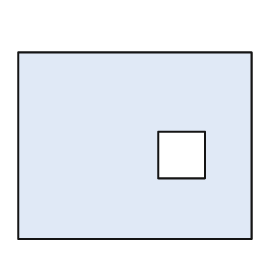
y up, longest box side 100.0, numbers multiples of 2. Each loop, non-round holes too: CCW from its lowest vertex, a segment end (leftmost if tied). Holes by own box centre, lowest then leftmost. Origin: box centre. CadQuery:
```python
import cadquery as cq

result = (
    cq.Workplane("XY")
    .moveTo(-50.0, -40.0)
    .lineTo(50.0, -40.0)
    .lineTo(50.0, 40.0)
    .lineTo(-50.0, 40.0)
    .close()
    .moveTo(10.0, -14.0)
    .lineTo(30.0, -14.0)
    .lineTo(30.0, 6.0)
    .lineTo(10.0, 6.0)
    .close()
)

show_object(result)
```